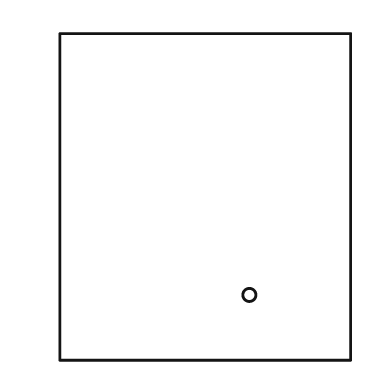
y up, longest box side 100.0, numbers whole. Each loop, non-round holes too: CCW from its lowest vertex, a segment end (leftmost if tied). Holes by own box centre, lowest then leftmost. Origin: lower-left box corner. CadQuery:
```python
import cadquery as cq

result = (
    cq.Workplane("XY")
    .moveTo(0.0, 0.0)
    .lineTo(89.0, 0.0)
    .lineTo(89.0, 100.0)
    .lineTo(0.0, 100.0)
    .close()
    .moveTo(58.0, 20.0)
    .circle(2.0)
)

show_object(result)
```